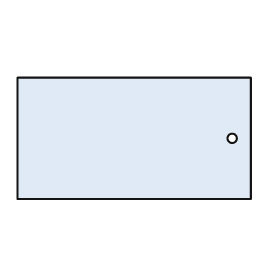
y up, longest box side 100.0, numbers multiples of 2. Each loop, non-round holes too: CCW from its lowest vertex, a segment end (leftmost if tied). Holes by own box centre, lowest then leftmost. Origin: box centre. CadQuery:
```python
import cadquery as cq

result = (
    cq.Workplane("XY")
    .moveTo(-50.0, -26.0)
    .lineTo(50.0, -26.0)
    .lineTo(50.0, 26.0)
    .lineTo(-50.0, 26.0)
    .close()
    .moveTo(42.0, 0.0)
    .circle(2.0)
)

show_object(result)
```